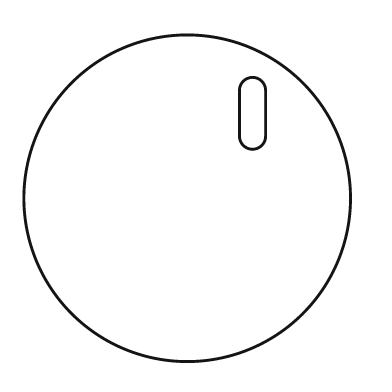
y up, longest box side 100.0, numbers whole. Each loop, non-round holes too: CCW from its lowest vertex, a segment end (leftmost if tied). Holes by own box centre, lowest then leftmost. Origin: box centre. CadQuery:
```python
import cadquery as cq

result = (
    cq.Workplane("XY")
    .moveTo(0.0, 0.0)
    .circle(50.0)
    .moveTo(16.0, 19.0)
    .threePointArc((20.0, 15.0), (24.0, 19.0))
    .lineTo(24.0, 33.0)
    .threePointArc((20.0, 37.0), (16.0, 33.0))
    .close()
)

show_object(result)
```